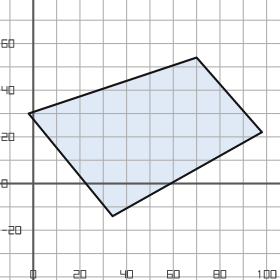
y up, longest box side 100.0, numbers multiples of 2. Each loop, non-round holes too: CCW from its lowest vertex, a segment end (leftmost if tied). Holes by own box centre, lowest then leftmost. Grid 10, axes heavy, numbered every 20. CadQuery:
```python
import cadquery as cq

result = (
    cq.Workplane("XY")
    .moveTo(34.0, -14.0)
    .lineTo(98.0, 22.0)
    .lineTo(70.0, 54.0)
    .lineTo(-2.0, 30.0)
    .close()
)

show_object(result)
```